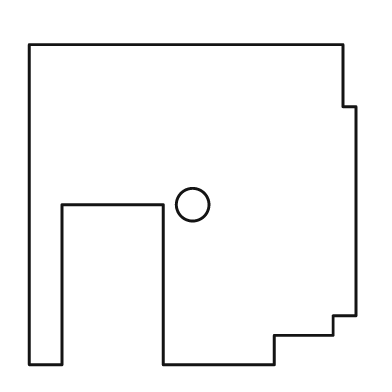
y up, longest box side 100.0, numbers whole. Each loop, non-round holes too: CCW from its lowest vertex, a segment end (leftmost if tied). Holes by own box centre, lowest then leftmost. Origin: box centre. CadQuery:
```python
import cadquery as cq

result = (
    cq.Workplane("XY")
    .moveTo(-50.0, -49.0)
    .lineTo(-40.0, -49.0)
    .lineTo(-40.0, 0.0)
    .lineTo(-9.0, 0.0)
    .lineTo(-9.0, -49.0)
    .lineTo(25.0, -49.0)
    .lineTo(25.0, -40.0)
    .lineTo(43.0, -40.0)
    .lineTo(43.0, -34.0)
    .lineTo(50.0, -34.0)
    .lineTo(50.0, 30.0)
    .lineTo(46.0, 30.0)
    .lineTo(46.0, 49.0)
    .lineTo(-50.0, 49.0)
    .close()
    .moveTo(0.0, 0.0)
    .circle(5.0)
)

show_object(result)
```